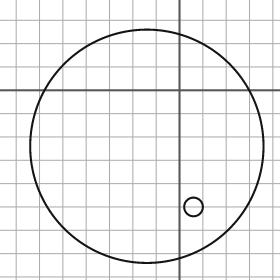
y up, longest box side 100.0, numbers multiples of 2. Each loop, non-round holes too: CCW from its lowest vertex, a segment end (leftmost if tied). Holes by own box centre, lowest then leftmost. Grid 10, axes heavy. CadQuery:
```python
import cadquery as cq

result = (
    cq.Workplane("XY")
    .moveTo(-14.0, -24.0)
    .circle(50.0)
    .moveTo(6.0, -50.0)
    .circle(4.0)
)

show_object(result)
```